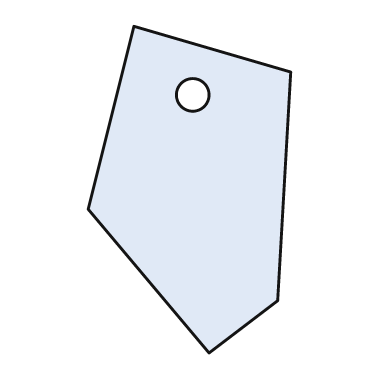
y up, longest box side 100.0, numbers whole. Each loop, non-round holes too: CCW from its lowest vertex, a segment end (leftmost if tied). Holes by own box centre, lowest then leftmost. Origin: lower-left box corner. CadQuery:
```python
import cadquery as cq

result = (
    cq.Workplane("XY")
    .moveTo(37.0, 0.0)
    .lineTo(58.0, 16.0)
    .lineTo(62.0, 86.0)
    .lineTo(14.0, 100.0)
    .lineTo(0.0, 44.0)
    .close()
    .moveTo(32.0, 79.0)
    .circle(5.0)
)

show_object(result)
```